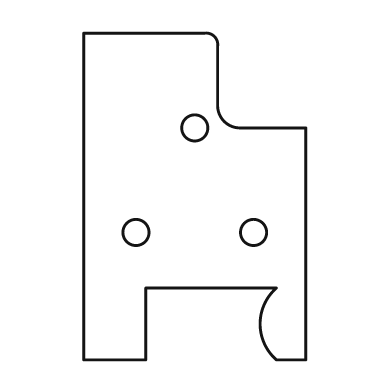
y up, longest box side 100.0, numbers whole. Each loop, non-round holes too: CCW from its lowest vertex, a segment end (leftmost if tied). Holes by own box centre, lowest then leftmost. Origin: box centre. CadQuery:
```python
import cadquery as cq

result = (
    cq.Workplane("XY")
    .moveTo(-34.0, -50.0)
    .lineTo(-15.0, -50.0)
    .lineTo(-15.0, -28.0)
    .lineTo(25.0, -28.0)
    .threePointArc((20.0, -39.0), (25.0, -50.0))
    .lineTo(34.0, -50.0)
    .lineTo(34.0, 21.0)
    .lineTo(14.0, 21.0)
    .threePointArc((9.0, 23.0), (7.0, 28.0))
    .lineTo(7.0, 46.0)
    .threePointArc((6.0, 49.0), (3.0, 50.0))
    .lineTo(-34.0, 50.0)
    .close()
    .moveTo(-18.0, -11.0)
    .circle(4.0)
    .moveTo(18.0, -11.0)
    .circle(4.0)
    .moveTo(0.0, 21.0)
    .circle(4.0)
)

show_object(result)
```